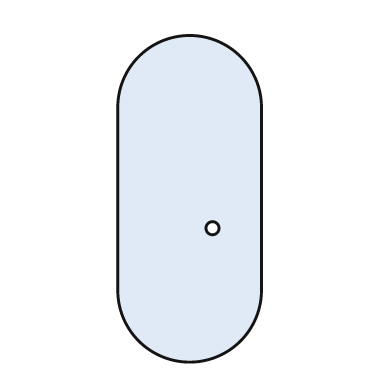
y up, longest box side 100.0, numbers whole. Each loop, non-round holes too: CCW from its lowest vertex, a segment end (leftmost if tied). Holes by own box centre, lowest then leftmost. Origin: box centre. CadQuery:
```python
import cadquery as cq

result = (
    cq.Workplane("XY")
    .moveTo(-22.0, -28.0)
    .threePointArc((0.0, -50.0), (22.0, -28.0))
    .lineTo(22.0, 28.0)
    .threePointArc((0.0, 50.0), (-22.0, 28.0))
    .close()
    .moveTo(7.0, -9.0)
    .circle(2.0)
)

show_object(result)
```